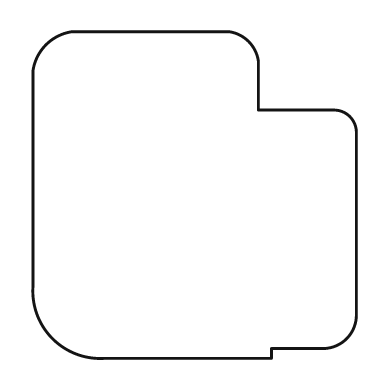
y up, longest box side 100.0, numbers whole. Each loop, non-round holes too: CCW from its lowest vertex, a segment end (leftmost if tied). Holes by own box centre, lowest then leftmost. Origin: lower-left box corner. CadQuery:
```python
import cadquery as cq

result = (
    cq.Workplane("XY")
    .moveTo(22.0, 0.0)
    .lineTo(73.0, 0.0)
    .lineTo(73.0, 3.0)
    .lineTo(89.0, 3.0)
    .threePointArc((96.0, 6.0), (99.0, 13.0))
    .lineTo(99.0, 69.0)
    .threePointArc((97.0, 74.0), (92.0, 76.0))
    .lineTo(69.0, 76.0)
    .lineTo(69.0, 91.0)
    .threePointArc((66.0, 97.0), (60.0, 100.0))
    .lineTo(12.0, 100.0)
    .threePointArc((4.0, 96.0), (0.0, 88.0))
    .lineTo(0.0, 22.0)
    .threePointArc((6.0, 6.0), (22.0, 0.0))
    .close()
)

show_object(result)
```